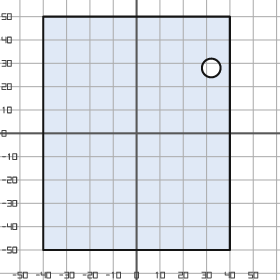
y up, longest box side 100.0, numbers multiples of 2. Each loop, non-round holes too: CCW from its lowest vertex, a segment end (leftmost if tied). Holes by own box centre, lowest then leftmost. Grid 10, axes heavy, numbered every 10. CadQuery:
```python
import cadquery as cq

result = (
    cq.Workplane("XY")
    .moveTo(-40.0, -50.0)
    .lineTo(40.0, -50.0)
    .lineTo(40.0, 50.0)
    .lineTo(-40.0, 50.0)
    .close()
    .moveTo(32.0, 28.0)
    .circle(4.0)
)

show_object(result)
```